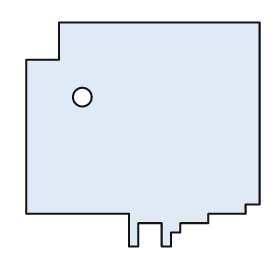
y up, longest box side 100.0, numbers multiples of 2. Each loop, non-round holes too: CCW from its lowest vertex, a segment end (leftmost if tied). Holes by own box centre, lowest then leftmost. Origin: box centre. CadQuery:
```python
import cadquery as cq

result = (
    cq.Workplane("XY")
    .moveTo(-6.0, -48.0)
    .lineTo(-2.0, -48.0)
    .lineTo(-2.0, -38.0)
    .lineTo(8.0, -38.0)
    .lineTo(8.0, -48.0)
    .lineTo(12.0, -48.0)
    .lineTo(12.0, -42.0)
    .lineTo(16.0, -42.0)
    .lineTo(16.0, -38.0)
    .lineTo(28.0, -38.0)
    .lineTo(28.0, -34.0)
    .lineTo(44.0, -34.0)
    .lineTo(44.0, -30.0)
    .lineTo(50.0, -30.0)
    .lineTo(50.0, 48.0)
    .lineTo(-36.0, 48.0)
    .lineTo(-36.0, 32.0)
    .lineTo(-50.0, 32.0)
    .lineTo(-50.0, -34.0)
    .lineTo(-6.0, -34.0)
    .close()
    .moveTo(-26.0, 16.0)
    .circle(4.0)
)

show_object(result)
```